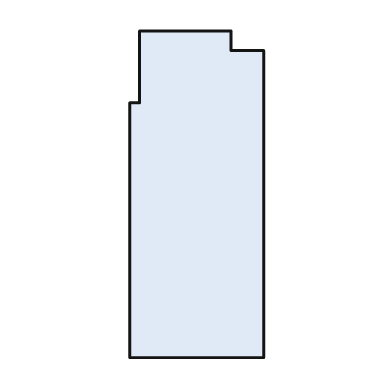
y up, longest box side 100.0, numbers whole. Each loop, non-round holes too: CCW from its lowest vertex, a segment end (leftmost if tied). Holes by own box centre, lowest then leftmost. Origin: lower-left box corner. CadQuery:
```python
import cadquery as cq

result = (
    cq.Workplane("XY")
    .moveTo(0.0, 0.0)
    .lineTo(41.0, 0.0)
    .lineTo(41.0, 94.0)
    .lineTo(31.0, 94.0)
    .lineTo(31.0, 100.0)
    .lineTo(3.0, 100.0)
    .lineTo(3.0, 78.0)
    .lineTo(0.0, 78.0)
    .close()
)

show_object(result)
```